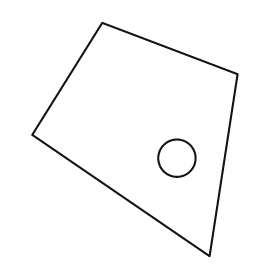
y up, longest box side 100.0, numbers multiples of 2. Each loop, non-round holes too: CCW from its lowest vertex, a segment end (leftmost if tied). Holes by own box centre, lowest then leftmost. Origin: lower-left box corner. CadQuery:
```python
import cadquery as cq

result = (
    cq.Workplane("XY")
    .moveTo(76.0, 0.0)
    .lineTo(88.0, 78.0)
    .lineTo(30.0, 100.0)
    .lineTo(0.0, 52.0)
    .close()
    .moveTo(62.0, 42.0)
    .circle(8.0)
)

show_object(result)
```